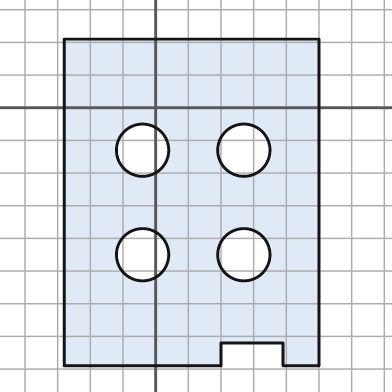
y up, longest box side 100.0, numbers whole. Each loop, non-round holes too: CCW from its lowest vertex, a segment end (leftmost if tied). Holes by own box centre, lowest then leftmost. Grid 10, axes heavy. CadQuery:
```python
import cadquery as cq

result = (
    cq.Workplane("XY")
    .moveTo(-28.0, -79.0)
    .lineTo(20.0, -79.0)
    .lineTo(20.0, -72.0)
    .lineTo(39.0, -72.0)
    .lineTo(39.0, -79.0)
    .lineTo(50.0, -79.0)
    .lineTo(50.0, 21.0)
    .lineTo(-28.0, 21.0)
    .close()
    .moveTo(-4.0, -45.0)
    .circle(8.0)
    .moveTo(27.0, -45.0)
    .circle(8.0)
    .moveTo(-4.0, -13.0)
    .circle(8.0)
    .moveTo(27.0, -13.0)
    .circle(8.0)
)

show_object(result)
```